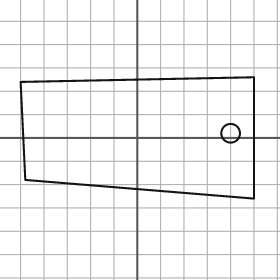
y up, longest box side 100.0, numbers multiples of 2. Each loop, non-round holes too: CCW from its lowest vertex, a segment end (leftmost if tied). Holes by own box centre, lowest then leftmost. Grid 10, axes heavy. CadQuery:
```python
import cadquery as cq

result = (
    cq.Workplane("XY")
    .moveTo(50.0, -26.0)
    .lineTo(50.0, 26.0)
    .lineTo(-50.0, 24.0)
    .lineTo(-48.0, -18.0)
    .close()
    .moveTo(40.0, 2.0)
    .circle(4.0)
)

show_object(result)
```